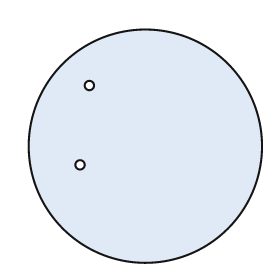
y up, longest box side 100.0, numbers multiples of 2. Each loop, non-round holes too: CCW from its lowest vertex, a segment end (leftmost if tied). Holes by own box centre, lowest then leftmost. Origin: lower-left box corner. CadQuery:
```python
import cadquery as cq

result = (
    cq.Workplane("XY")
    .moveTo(50.0, 50.0)
    .circle(50.0)
    .moveTo(22.0, 42.0)
    .circle(2.0)
    .moveTo(26.0, 76.0)
    .circle(2.0)
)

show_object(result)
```